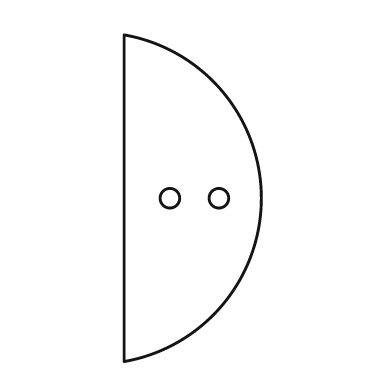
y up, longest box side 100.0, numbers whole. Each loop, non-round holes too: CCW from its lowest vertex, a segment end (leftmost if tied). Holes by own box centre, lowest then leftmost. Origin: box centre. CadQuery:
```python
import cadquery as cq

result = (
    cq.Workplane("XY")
    .moveTo(-21.0, -50.0)
    .threePointArc((21.0, 0.0), (-21.0, 50.0))
    .close()
    .moveTo(-7.0, 0.0)
    .circle(3.0)
    .moveTo(8.0, 0.0)
    .circle(3.0)
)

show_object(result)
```